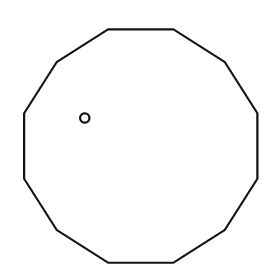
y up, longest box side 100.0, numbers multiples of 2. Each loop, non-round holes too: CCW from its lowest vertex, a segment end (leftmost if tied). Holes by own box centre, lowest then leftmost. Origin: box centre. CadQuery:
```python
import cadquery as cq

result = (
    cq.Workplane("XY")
    .moveTo(-14.0, -50.0)
    .lineTo(14.0, -50.0)
    .lineTo(36.0, -36.0)
    .lineTo(50.0, -14.0)
    .lineTo(50.0, 14.0)
    .lineTo(36.0, 36.0)
    .lineTo(14.0, 50.0)
    .lineTo(-14.0, 50.0)
    .lineTo(-36.0, 36.0)
    .lineTo(-50.0, 14.0)
    .lineTo(-50.0, -14.0)
    .lineTo(-36.0, -36.0)
    .close()
    .moveTo(-24.0, 12.0)
    .circle(2.0)
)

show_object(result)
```